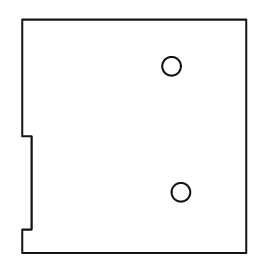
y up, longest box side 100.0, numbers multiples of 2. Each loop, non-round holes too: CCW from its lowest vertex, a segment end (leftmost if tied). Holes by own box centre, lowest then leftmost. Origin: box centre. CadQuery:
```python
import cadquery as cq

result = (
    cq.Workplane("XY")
    .moveTo(-48.0, -50.0)
    .lineTo(48.0, -50.0)
    .lineTo(48.0, 50.0)
    .lineTo(-48.0, 50.0)
    .lineTo(-48.0, 0.0)
    .lineTo(-44.0, 0.0)
    .lineTo(-44.0, -40.0)
    .lineTo(-48.0, -40.0)
    .close()
    .moveTo(20.0, -24.0)
    .circle(4.0)
    .moveTo(16.0, 30.0)
    .circle(4.0)
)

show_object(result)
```